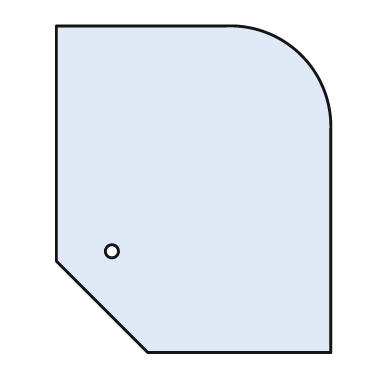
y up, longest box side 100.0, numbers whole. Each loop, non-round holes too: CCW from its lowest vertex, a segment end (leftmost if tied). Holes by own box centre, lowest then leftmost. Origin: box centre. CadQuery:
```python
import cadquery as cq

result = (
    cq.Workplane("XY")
    .moveTo(-14.0, -50.0)
    .lineTo(42.0, -50.0)
    .lineTo(42.0, 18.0)
    .threePointArc((33.0, 41.0), (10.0, 50.0))
    .lineTo(-42.0, 50.0)
    .lineTo(-42.0, -22.0)
    .close()
    .moveTo(-25.0, -19.0)
    .circle(2.0)
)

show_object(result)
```